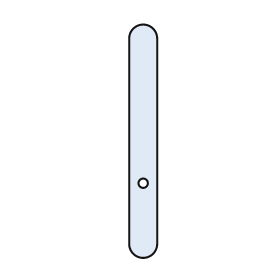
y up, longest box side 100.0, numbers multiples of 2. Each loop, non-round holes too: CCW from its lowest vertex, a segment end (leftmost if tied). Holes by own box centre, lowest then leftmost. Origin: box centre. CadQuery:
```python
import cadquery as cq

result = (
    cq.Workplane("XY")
    .moveTo(-6.0, -44.0)
    .threePointArc((0.0, -50.0), (6.0, -44.0))
    .lineTo(6.0, 44.0)
    .threePointArc((0.0, 50.0), (-6.0, 44.0))
    .close()
    .moveTo(0.0, -18.0)
    .circle(2.0)
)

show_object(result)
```